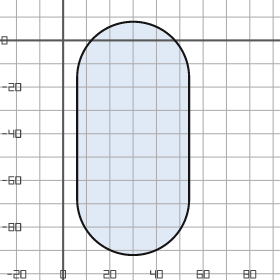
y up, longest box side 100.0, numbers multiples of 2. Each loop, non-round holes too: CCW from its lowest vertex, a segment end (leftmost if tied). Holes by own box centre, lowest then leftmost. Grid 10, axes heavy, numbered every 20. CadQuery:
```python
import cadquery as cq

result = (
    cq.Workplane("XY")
    .moveTo(6.0, -68.0)
    .threePointArc((30.0, -92.0), (54.0, -68.0))
    .lineTo(54.0, -16.0)
    .threePointArc((30.0, 8.0), (6.0, -16.0))
    .close()
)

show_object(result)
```